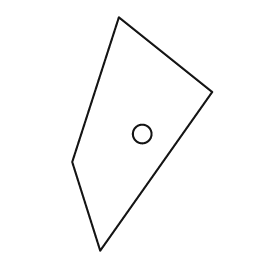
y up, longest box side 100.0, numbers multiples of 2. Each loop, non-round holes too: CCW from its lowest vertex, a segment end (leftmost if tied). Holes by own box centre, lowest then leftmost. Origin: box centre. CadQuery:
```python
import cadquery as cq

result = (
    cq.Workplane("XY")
    .moveTo(-18.0, -50.0)
    .lineTo(30.0, 18.0)
    .lineTo(-10.0, 50.0)
    .lineTo(-30.0, -12.0)
    .close()
    .moveTo(0.0, 0.0)
    .circle(4.0)
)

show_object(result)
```